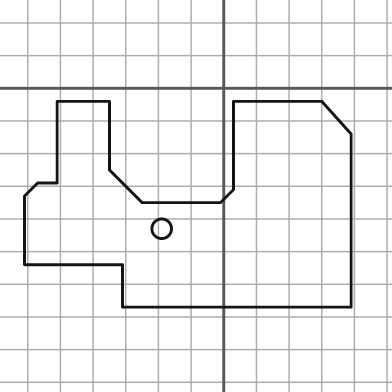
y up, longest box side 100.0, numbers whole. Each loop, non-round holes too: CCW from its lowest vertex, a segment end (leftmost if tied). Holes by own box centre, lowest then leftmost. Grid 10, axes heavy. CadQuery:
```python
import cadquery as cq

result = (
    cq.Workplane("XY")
    .moveTo(-31.0, -67.0)
    .lineTo(39.0, -67.0)
    .lineTo(39.0, -14.0)
    .lineTo(30.0, -4.0)
    .lineTo(3.0, -4.0)
    .lineTo(3.0, -31.0)
    .lineTo(-1.0, -35.0)
    .lineTo(-25.0, -35.0)
    .lineTo(-35.0, -25.0)
    .lineTo(-35.0, -4.0)
    .lineTo(-51.0, -4.0)
    .lineTo(-51.0, -29.0)
    .lineTo(-57.0, -29.0)
    .lineTo(-61.0, -33.0)
    .lineTo(-61.0, -54.0)
    .lineTo(-31.0, -54.0)
    .close()
    .moveTo(-19.0, -43.0)
    .circle(3.0)
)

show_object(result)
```